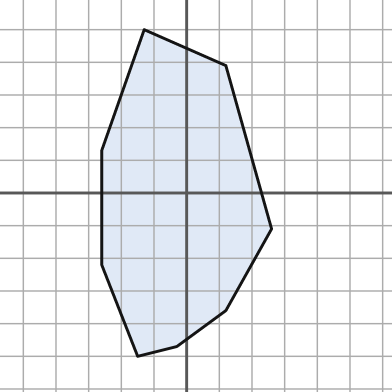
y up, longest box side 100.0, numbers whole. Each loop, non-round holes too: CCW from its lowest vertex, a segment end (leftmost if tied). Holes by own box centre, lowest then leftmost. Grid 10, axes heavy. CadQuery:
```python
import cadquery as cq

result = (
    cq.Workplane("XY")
    .moveTo(-15.0, -50.0)
    .lineTo(-3.0, -47.0)
    .lineTo(12.0, -36.0)
    .lineTo(26.0, -11.0)
    .lineTo(12.0, 39.0)
    .lineTo(-13.0, 50.0)
    .lineTo(-26.0, 13.0)
    .lineTo(-26.0, -22.0)
    .close()
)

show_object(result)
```